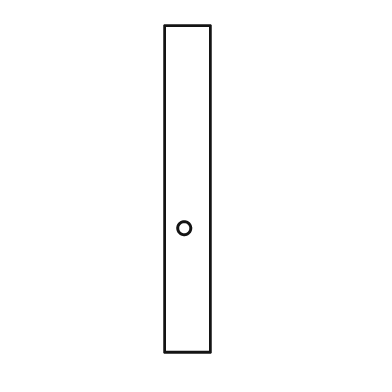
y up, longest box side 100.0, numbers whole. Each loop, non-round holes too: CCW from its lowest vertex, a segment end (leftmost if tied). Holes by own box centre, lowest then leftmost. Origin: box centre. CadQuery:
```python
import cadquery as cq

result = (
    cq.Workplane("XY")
    .moveTo(-7.0, -50.0)
    .lineTo(7.0, -50.0)
    .lineTo(7.0, 50.0)
    .lineTo(-7.0, 50.0)
    .close()
    .moveTo(-1.0, -12.0)
    .circle(2.0)
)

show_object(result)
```